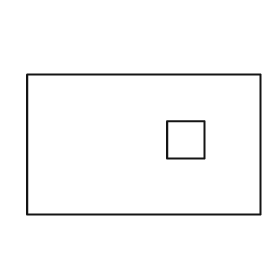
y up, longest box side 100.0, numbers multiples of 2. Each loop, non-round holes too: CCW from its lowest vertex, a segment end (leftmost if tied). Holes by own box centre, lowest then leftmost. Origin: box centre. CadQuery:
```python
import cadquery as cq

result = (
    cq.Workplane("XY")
    .moveTo(-50.0, -30.0)
    .lineTo(50.0, -30.0)
    .lineTo(50.0, 30.0)
    .lineTo(-50.0, 30.0)
    .close()
    .moveTo(10.0, -6.0)
    .lineTo(26.0, -6.0)
    .lineTo(26.0, 10.0)
    .lineTo(10.0, 10.0)
    .close()
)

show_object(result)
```